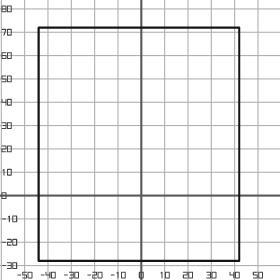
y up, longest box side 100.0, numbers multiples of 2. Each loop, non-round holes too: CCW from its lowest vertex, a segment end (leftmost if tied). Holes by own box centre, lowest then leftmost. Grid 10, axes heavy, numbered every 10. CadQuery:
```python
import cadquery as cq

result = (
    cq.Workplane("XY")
    .moveTo(-44.0, -28.0)
    .lineTo(42.0, -28.0)
    .lineTo(42.0, 72.0)
    .lineTo(-44.0, 72.0)
    .close()
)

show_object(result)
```